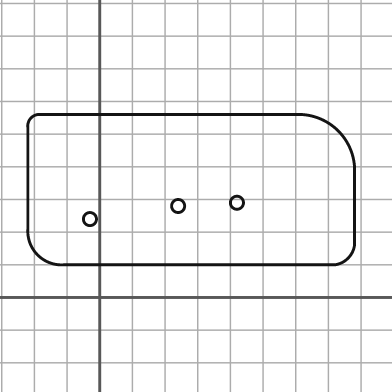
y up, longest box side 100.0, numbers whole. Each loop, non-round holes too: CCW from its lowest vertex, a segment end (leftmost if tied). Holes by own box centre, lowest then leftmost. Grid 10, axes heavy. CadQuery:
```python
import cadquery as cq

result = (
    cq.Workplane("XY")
    .moveTo(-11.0, 10.0)
    .lineTo(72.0, 10.0)
    .threePointArc((76.0, 12.0), (78.0, 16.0))
    .lineTo(78.0, 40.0)
    .threePointArc((73.0, 51.0), (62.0, 56.0))
    .lineTo(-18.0, 56.0)
    .threePointArc((-21.0, 55.0), (-22.0, 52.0))
    .lineTo(-22.0, 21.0)
    .threePointArc((-19.0, 13.0), (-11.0, 10.0))
    .close()
    .moveTo(-3.0, 24.0)
    .circle(2.0)
    .moveTo(24.0, 28.0)
    .circle(2.0)
    .moveTo(42.0, 29.0)
    .circle(2.0)
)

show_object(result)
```